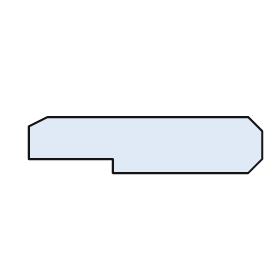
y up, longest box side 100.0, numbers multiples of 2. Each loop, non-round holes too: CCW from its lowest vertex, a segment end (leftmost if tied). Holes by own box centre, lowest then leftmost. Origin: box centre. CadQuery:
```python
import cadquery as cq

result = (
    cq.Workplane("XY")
    .moveTo(-14.0, -12.0)
    .lineTo(44.0, -12.0)
    .lineTo(50.0, -6.0)
    .lineTo(50.0, 6.0)
    .lineTo(44.0, 12.0)
    .lineTo(-42.0, 12.0)
    .lineTo(-50.0, 8.0)
    .lineTo(-50.0, -6.0)
    .lineTo(-14.0, -6.0)
    .close()
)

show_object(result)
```